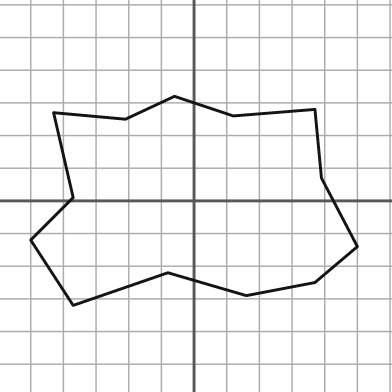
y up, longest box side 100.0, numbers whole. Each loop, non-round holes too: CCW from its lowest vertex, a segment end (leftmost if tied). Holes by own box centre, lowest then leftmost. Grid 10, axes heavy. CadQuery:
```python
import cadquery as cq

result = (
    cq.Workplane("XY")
    .moveTo(-37.0, -32.0)
    .lineTo(-8.0, -22.0)
    .lineTo(16.0, -29.0)
    .lineTo(37.0, -25.0)
    .lineTo(50.0, -14.0)
    .lineTo(39.0, 7.0)
    .lineTo(37.0, 28.0)
    .lineTo(12.0, 26.0)
    .lineTo(-6.0, 32.0)
    .lineTo(-21.0, 25.0)
    .lineTo(-43.0, 27.0)
    .lineTo(-37.0, 1.0)
    .lineTo(-50.0, -12.0)
    .close()
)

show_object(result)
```